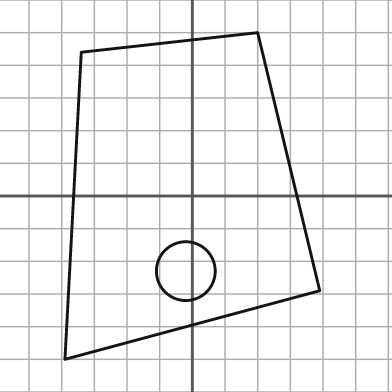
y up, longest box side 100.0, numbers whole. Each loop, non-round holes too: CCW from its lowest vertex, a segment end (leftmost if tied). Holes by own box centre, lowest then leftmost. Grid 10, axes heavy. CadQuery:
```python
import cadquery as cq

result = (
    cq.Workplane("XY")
    .moveTo(-39.0, -50.0)
    .lineTo(39.0, -29.0)
    .lineTo(20.0, 50.0)
    .lineTo(-34.0, 44.0)
    .close()
    .moveTo(-2.0, -23.0)
    .circle(9.0)
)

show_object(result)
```